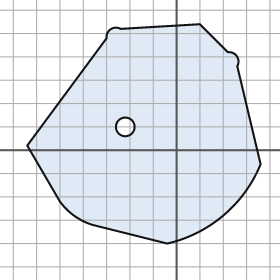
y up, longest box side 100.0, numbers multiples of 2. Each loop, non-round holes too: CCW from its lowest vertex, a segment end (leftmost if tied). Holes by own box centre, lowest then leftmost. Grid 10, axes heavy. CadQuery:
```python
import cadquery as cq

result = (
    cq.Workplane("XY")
    .moveTo(-4.0, -40.0)
    .threePointArc((20.0, -28.0), (36.0, -6.0))
    .lineTo(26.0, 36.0)
    .threePointArc((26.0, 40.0), (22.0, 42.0))
    .lineTo(10.0, 54.0)
    .lineTo(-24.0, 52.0)
    .threePointArc((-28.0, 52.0), (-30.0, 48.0))
    .lineTo(-64.0, 2.0)
    .lineTo(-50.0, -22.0)
    .threePointArc((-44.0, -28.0), (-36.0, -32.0))
    .close()
    .moveTo(-22.0, 10.0)
    .circle(4.0)
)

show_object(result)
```